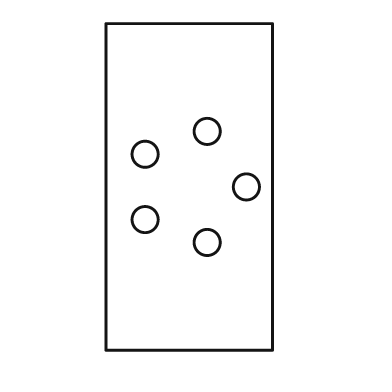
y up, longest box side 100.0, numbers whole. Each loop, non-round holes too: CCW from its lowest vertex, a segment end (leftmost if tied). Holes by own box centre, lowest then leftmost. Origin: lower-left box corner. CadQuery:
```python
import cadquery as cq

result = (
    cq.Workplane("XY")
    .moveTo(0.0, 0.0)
    .lineTo(51.0, 0.0)
    .lineTo(51.0, 100.0)
    .lineTo(0.0, 100.0)
    .close()
    .moveTo(31.0, 33.0)
    .circle(4.0)
    .moveTo(12.0, 40.0)
    .circle(4.0)
    .moveTo(43.0, 50.0)
    .circle(4.0)
    .moveTo(12.0, 60.0)
    .circle(4.0)
    .moveTo(31.0, 67.0)
    .circle(4.0)
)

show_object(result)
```